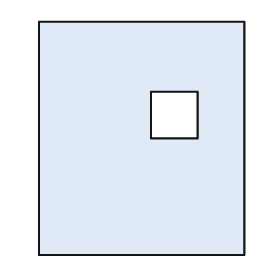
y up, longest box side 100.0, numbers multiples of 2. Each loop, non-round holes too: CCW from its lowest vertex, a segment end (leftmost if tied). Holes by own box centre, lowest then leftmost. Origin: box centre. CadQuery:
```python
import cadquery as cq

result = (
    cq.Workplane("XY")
    .moveTo(-44.0, -50.0)
    .lineTo(44.0, -50.0)
    .lineTo(44.0, 50.0)
    .lineTo(-44.0, 50.0)
    .close()
    .moveTo(4.0, 0.0)
    .lineTo(24.0, 0.0)
    .lineTo(24.0, 20.0)
    .lineTo(4.0, 20.0)
    .close()
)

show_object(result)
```